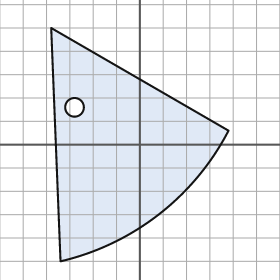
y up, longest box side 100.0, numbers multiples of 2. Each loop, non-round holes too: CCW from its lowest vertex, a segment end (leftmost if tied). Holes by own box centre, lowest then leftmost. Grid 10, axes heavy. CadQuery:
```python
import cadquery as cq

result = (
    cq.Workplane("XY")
    .moveTo(-34.0, -50.0)
    .threePointArc((8.0, -30.0), (38.0, 6.0))
    .lineTo(-38.0, 50.0)
    .close()
    .moveTo(-28.0, 16.0)
    .circle(4.0)
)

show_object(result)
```